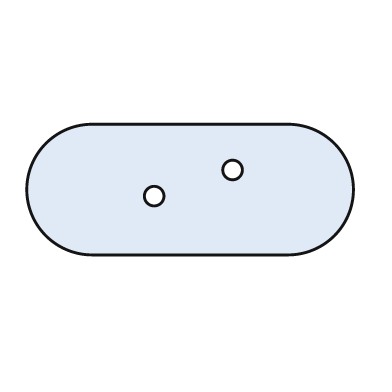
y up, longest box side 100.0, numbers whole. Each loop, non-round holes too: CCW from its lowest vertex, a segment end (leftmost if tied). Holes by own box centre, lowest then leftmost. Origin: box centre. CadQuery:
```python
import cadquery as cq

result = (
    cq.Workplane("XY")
    .moveTo(-30.0, -20.0)
    .lineTo(30.0, -20.0)
    .threePointArc((50.0, 0.0), (30.0, 20.0))
    .lineTo(-30.0, 20.0)
    .threePointArc((-50.0, 0.0), (-30.0, -20.0))
    .close()
    .moveTo(-11.0, -2.0)
    .circle(3.0)
    .moveTo(13.0, 6.0)
    .circle(3.0)
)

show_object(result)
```